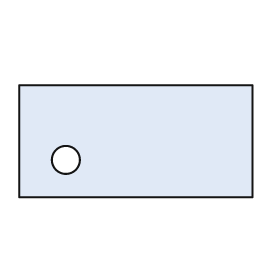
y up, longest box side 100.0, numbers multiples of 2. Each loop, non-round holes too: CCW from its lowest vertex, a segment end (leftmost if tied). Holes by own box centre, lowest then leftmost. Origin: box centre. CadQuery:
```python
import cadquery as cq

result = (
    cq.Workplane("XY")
    .moveTo(-50.0, -24.0)
    .lineTo(50.0, -24.0)
    .lineTo(50.0, 24.0)
    .lineTo(-50.0, 24.0)
    .close()
    .moveTo(-30.0, -8.0)
    .circle(6.0)
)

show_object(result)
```